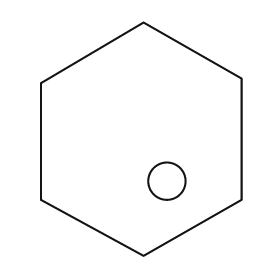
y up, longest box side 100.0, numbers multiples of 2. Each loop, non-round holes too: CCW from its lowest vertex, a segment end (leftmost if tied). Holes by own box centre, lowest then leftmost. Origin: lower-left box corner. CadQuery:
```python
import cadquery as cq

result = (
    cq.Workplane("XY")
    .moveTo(44.0, 0.0)
    .lineTo(86.0, 24.0)
    .lineTo(86.0, 76.0)
    .lineTo(44.0, 100.0)
    .lineTo(0.0, 74.0)
    .lineTo(0.0, 24.0)
    .close()
    .moveTo(54.0, 32.0)
    .circle(8.0)
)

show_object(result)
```